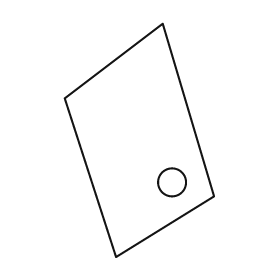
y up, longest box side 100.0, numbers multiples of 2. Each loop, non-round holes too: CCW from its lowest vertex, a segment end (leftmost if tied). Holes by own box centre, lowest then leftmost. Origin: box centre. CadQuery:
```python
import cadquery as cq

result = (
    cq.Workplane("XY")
    .moveTo(-10.0, -50.0)
    .lineTo(32.0, -24.0)
    .lineTo(10.0, 50.0)
    .lineTo(-32.0, 18.0)
    .close()
    .moveTo(14.0, -18.0)
    .circle(6.0)
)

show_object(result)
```